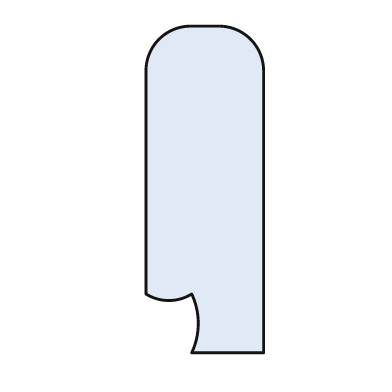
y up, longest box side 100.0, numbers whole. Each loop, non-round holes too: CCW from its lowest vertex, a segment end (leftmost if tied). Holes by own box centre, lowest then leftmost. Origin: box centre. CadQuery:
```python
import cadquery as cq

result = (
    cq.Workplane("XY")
    .moveTo(-4.0, -50.0)
    .lineTo(18.0, -50.0)
    .lineTo(18.0, 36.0)
    .threePointArc((14.0, 46.0), (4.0, 50.0))
    .lineTo(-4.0, 50.0)
    .threePointArc((-14.0, 46.0), (-18.0, 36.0))
    .lineTo(-18.0, -32.0)
    .threePointArc((-11.0, -34.0), (-4.0, -32.0))
    .threePointArc((-2.0, -41.0), (-4.0, -50.0))
    .close()
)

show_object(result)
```